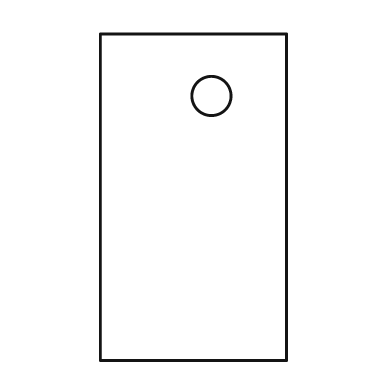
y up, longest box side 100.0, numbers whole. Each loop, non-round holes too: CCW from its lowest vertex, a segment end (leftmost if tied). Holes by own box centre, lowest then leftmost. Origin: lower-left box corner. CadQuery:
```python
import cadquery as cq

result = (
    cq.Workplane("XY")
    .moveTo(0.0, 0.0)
    .lineTo(57.0, 0.0)
    .lineTo(57.0, 100.0)
    .lineTo(0.0, 100.0)
    .close()
    .moveTo(34.0, 81.0)
    .circle(6.0)
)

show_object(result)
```